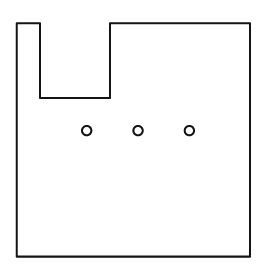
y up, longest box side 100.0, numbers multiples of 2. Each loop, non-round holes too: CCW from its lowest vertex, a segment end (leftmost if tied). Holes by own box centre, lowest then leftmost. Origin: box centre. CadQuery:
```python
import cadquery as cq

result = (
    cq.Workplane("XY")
    .moveTo(-50.0, -50.0)
    .lineTo(50.0, -50.0)
    .lineTo(50.0, 50.0)
    .lineTo(-10.0, 50.0)
    .lineTo(-10.0, 18.0)
    .lineTo(-40.0, 18.0)
    .lineTo(-40.0, 50.0)
    .lineTo(-50.0, 50.0)
    .close()
    .moveTo(-20.0, 4.0)
    .circle(2.0)
    .moveTo(2.0, 4.0)
    .circle(2.0)
    .moveTo(24.0, 4.0)
    .circle(2.0)
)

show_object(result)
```